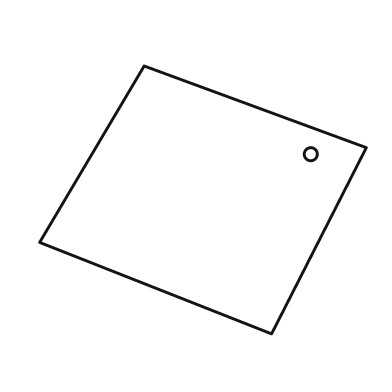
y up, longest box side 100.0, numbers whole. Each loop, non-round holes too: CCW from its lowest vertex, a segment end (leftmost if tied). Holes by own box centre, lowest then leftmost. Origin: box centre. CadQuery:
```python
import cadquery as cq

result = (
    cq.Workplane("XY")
    .moveTo(21.0, -41.0)
    .lineTo(50.0, 16.0)
    .lineTo(-18.0, 41.0)
    .lineTo(-50.0, -13.0)
    .close()
    .moveTo(33.0, 14.0)
    .circle(2.0)
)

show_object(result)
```